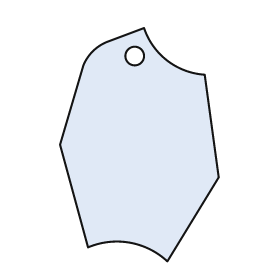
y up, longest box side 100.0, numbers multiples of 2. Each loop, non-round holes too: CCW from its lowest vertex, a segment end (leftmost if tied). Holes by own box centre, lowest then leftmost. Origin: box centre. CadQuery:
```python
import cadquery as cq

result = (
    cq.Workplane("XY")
    .moveTo(12.0, -50.0)
    .lineTo(34.0, -14.0)
    .lineTo(28.0, 30.0)
    .threePointArc((12.0, 36.0), (2.0, 50.0))
    .lineTo(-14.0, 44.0)
    .threePointArc((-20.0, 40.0), (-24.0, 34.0))
    .lineTo(-34.0, 0.0)
    .lineTo(-22.0, -44.0)
    .threePointArc((-4.0, -42.0), (12.0, -50.0))
    .close()
    .moveTo(-2.0, 38.0)
    .circle(4.0)
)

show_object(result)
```